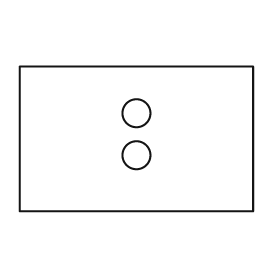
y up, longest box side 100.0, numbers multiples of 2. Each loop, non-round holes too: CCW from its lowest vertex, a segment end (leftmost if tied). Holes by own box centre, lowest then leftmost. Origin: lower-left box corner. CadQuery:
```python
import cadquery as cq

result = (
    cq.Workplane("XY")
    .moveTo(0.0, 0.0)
    .lineTo(100.0, 0.0)
    .lineTo(100.0, 62.0)
    .lineTo(0.0, 62.0)
    .close()
    .moveTo(50.0, 24.0)
    .circle(6.0)
    .moveTo(50.0, 42.0)
    .circle(6.0)
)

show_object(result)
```